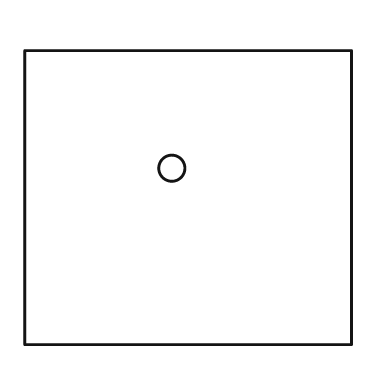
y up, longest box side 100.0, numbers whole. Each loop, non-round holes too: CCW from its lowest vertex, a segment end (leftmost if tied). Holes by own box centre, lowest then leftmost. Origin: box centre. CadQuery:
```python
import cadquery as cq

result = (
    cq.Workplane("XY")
    .moveTo(-50.0, -45.0)
    .lineTo(50.0, -45.0)
    .lineTo(50.0, 45.0)
    .lineTo(-50.0, 45.0)
    .close()
    .moveTo(-5.0, 9.0)
    .circle(4.0)
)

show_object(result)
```